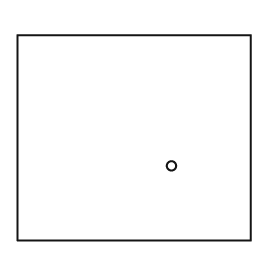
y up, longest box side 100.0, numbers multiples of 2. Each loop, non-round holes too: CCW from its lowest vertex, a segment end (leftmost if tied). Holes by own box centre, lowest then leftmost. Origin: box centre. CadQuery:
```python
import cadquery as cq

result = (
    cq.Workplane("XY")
    .moveTo(-50.0, -44.0)
    .lineTo(50.0, -44.0)
    .lineTo(50.0, 44.0)
    .lineTo(-50.0, 44.0)
    .close()
    .moveTo(16.0, -12.0)
    .circle(2.0)
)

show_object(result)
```